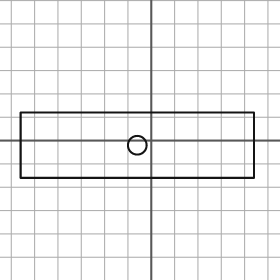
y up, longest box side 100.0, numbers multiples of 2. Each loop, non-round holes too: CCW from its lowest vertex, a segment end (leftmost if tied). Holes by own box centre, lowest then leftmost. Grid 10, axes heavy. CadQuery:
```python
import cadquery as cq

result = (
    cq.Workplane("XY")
    .moveTo(-56.0, -16.0)
    .lineTo(44.0, -16.0)
    .lineTo(44.0, 12.0)
    .lineTo(-56.0, 12.0)
    .close()
    .moveTo(-6.0, -2.0)
    .circle(4.0)
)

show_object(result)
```